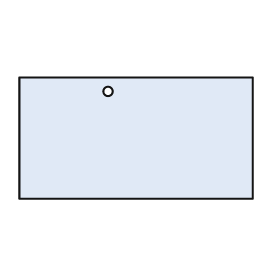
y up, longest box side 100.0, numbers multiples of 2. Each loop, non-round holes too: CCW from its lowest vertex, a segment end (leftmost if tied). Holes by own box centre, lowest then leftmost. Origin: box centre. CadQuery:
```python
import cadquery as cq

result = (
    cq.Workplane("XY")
    .moveTo(-50.0, -26.0)
    .lineTo(50.0, -26.0)
    .lineTo(50.0, 26.0)
    .lineTo(-50.0, 26.0)
    .close()
    .moveTo(-12.0, 20.0)
    .circle(2.0)
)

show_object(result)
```